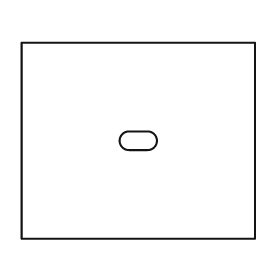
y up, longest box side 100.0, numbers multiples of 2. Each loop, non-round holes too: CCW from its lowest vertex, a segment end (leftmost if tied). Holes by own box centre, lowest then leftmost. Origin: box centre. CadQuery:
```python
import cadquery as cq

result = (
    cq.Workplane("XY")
    .moveTo(-50.0, -42.0)
    .lineTo(50.0, -42.0)
    .lineTo(50.0, 42.0)
    .lineTo(-50.0, 42.0)
    .close()
    .moveTo(-4.0, -4.0)
    .lineTo(4.0, -4.0)
    .threePointArc((8.0, 0.0), (4.0, 4.0))
    .lineTo(-4.0, 4.0)
    .threePointArc((-8.0, 0.0), (-4.0, -4.0))
    .close()
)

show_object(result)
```